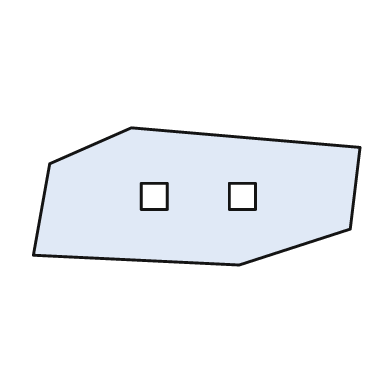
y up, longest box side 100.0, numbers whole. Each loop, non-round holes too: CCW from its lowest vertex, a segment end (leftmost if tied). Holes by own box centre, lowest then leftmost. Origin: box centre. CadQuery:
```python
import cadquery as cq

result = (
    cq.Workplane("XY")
    .moveTo(13.0, -21.0)
    .lineTo(47.0, -10.0)
    .lineTo(50.0, 15.0)
    .lineTo(-20.0, 21.0)
    .lineTo(-45.0, 10.0)
    .lineTo(-50.0, -18.0)
    .close()
    .moveTo(-17.0, -4.0)
    .lineTo(-9.0, -4.0)
    .lineTo(-9.0, 4.0)
    .lineTo(-17.0, 4.0)
    .close()
    .moveTo(10.0, -4.0)
    .lineTo(18.0, -4.0)
    .lineTo(18.0, 4.0)
    .lineTo(10.0, 4.0)
    .close()
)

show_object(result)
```